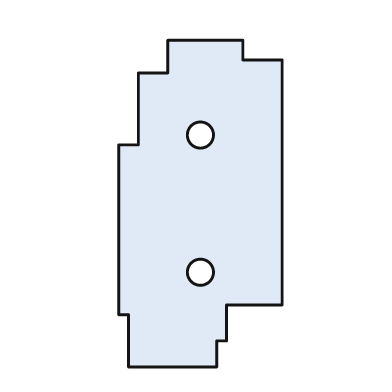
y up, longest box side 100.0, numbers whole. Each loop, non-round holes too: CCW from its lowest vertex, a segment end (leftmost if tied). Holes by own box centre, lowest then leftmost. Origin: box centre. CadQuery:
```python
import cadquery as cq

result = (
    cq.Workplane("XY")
    .moveTo(-22.0, -50.0)
    .lineTo(5.0, -50.0)
    .lineTo(5.0, -42.0)
    .lineTo(8.0, -42.0)
    .lineTo(8.0, -31.0)
    .lineTo(25.0, -31.0)
    .lineTo(25.0, 44.0)
    .lineTo(13.0, 44.0)
    .lineTo(13.0, 50.0)
    .lineTo(-10.0, 50.0)
    .lineTo(-10.0, 40.0)
    .lineTo(-19.0, 40.0)
    .lineTo(-19.0, 18.0)
    .lineTo(-25.0, 18.0)
    .lineTo(-25.0, -34.0)
    .lineTo(-22.0, -34.0)
    .close()
    .moveTo(0.0, -21.0)
    .circle(4.0)
    .moveTo(0.0, 21.0)
    .circle(4.0)
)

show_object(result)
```